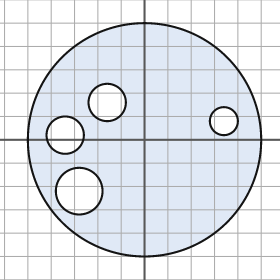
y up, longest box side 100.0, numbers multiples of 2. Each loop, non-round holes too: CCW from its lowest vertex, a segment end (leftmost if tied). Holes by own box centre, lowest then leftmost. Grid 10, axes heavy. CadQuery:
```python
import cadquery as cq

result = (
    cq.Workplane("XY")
    .moveTo(0.0, 0.0)
    .circle(50.0)
    .moveTo(-28.0, -22.0)
    .circle(10.0)
    .moveTo(-34.0, 2.0)
    .circle(8.0)
    .moveTo(34.0, 8.0)
    .circle(6.0)
    .moveTo(-16.0, 16.0)
    .circle(8.0)
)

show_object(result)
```